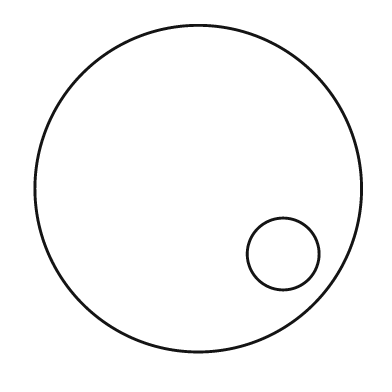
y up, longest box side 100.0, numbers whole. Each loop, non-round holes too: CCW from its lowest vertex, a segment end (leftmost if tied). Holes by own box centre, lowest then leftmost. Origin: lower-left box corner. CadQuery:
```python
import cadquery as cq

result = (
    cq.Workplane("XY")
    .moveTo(50.0, 50.0)
    .circle(50.0)
    .moveTo(76.0, 30.0)
    .circle(11.0)
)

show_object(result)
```